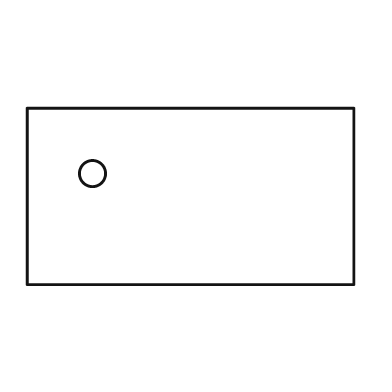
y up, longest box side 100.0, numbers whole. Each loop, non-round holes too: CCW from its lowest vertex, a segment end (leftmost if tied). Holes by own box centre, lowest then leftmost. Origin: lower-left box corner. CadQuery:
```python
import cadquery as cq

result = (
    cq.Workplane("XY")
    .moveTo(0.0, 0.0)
    .lineTo(100.0, 0.0)
    .lineTo(100.0, 54.0)
    .lineTo(0.0, 54.0)
    .close()
    .moveTo(20.0, 34.0)
    .circle(4.0)
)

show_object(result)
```